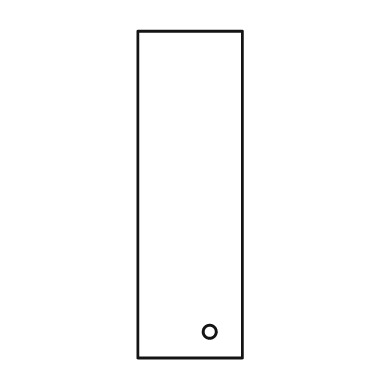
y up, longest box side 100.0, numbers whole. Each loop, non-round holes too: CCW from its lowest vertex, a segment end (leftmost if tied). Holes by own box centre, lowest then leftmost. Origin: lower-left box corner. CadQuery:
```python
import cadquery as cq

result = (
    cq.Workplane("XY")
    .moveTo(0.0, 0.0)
    .lineTo(32.0, 0.0)
    .lineTo(32.0, 100.0)
    .lineTo(0.0, 100.0)
    .close()
    .moveTo(22.0, 8.0)
    .circle(2.0)
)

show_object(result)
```